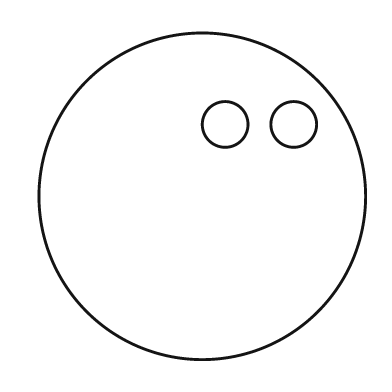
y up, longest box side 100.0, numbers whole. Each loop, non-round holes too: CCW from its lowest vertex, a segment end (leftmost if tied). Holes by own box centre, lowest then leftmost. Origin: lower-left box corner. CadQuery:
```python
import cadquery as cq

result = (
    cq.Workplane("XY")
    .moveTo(50.0, 50.0)
    .circle(50.0)
    .moveTo(57.0, 72.0)
    .circle(7.0)
    .moveTo(78.0, 72.0)
    .circle(7.0)
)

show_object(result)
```